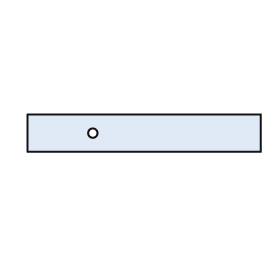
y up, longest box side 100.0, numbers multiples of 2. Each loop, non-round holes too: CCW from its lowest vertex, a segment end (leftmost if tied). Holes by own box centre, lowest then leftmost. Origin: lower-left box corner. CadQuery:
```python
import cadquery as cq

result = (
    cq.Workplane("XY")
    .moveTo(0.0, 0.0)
    .lineTo(100.0, 0.0)
    .lineTo(100.0, 16.0)
    .lineTo(0.0, 16.0)
    .close()
    .moveTo(28.0, 8.0)
    .circle(2.0)
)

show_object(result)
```